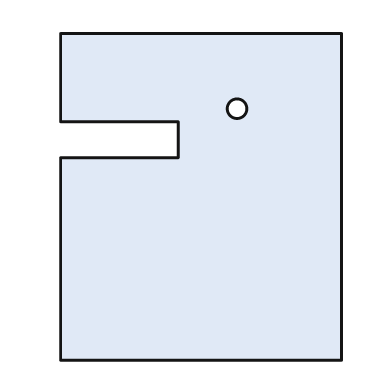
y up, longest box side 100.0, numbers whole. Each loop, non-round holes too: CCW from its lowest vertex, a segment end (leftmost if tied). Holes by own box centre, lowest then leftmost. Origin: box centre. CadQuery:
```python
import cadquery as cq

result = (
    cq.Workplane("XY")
    .moveTo(-43.0, -50.0)
    .lineTo(43.0, -50.0)
    .lineTo(43.0, 50.0)
    .lineTo(-43.0, 50.0)
    .lineTo(-43.0, 23.0)
    .lineTo(-7.0, 23.0)
    .lineTo(-7.0, 12.0)
    .lineTo(-43.0, 12.0)
    .close()
    .moveTo(11.0, 27.0)
    .circle(3.0)
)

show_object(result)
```